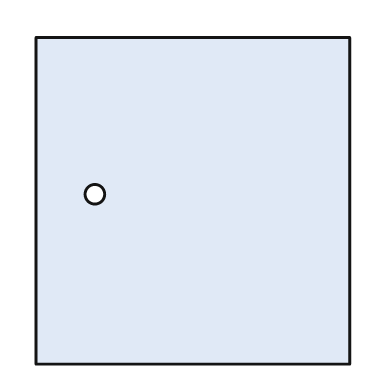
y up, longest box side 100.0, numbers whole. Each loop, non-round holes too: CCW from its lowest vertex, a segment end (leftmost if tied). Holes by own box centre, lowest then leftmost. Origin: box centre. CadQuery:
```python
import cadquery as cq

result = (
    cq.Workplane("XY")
    .moveTo(-48.0, -50.0)
    .lineTo(48.0, -50.0)
    .lineTo(48.0, 50.0)
    .lineTo(-48.0, 50.0)
    .close()
    .moveTo(-30.0, 2.0)
    .circle(3.0)
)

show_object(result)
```